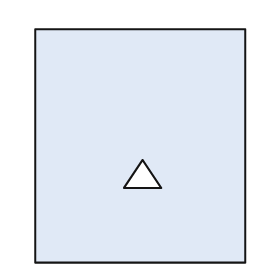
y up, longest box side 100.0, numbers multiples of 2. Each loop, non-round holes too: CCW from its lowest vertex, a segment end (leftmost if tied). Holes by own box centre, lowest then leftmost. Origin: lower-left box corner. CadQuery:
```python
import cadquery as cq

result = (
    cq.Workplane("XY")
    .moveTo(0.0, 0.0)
    .lineTo(90.0, 0.0)
    .lineTo(90.0, 100.0)
    .lineTo(0.0, 100.0)
    .close()
    .moveTo(38.0, 32.0)
    .lineTo(54.0, 32.0)
    .lineTo(46.0, 44.0)
    .close()
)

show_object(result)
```